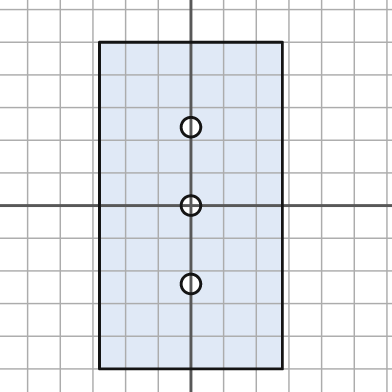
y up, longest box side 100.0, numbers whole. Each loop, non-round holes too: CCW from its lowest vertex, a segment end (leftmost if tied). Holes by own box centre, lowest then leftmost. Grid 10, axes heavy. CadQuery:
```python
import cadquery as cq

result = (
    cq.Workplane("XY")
    .moveTo(-28.0, -50.0)
    .lineTo(28.0, -50.0)
    .lineTo(28.0, 50.0)
    .lineTo(-28.0, 50.0)
    .close()
    .moveTo(0.0, -24.0)
    .circle(3.0)
    .moveTo(0.0, 0.0)
    .circle(3.0)
    .moveTo(0.0, 24.0)
    .circle(3.0)
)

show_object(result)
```